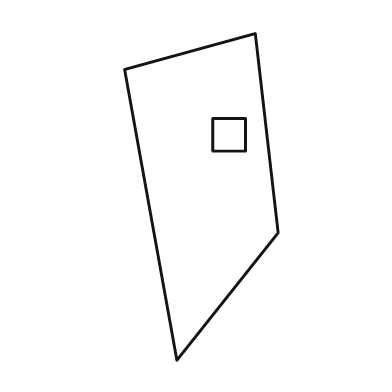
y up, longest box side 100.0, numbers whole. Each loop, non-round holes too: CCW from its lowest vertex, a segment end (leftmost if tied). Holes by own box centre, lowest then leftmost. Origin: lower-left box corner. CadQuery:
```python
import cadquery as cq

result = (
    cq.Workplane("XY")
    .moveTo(16.0, 0.0)
    .lineTo(47.0, 39.0)
    .lineTo(40.0, 100.0)
    .lineTo(0.0, 89.0)
    .close()
    .moveTo(27.0, 64.0)
    .lineTo(37.0, 64.0)
    .lineTo(37.0, 74.0)
    .lineTo(27.0, 74.0)
    .close()
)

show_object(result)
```